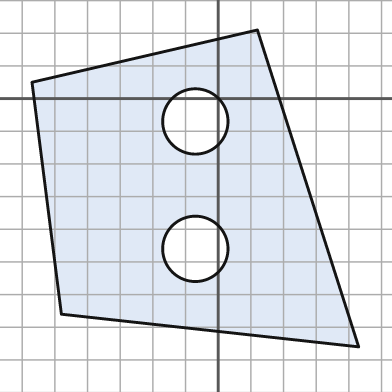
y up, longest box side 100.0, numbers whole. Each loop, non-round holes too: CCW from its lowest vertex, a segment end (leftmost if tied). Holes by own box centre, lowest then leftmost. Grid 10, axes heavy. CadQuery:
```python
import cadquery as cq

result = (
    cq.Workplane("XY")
    .moveTo(43.0, -76.0)
    .lineTo(12.0, 21.0)
    .lineTo(-57.0, 5.0)
    .lineTo(-48.0, -66.0)
    .close()
    .moveTo(-7.0, -46.0)
    .circle(10.0)
    .moveTo(-7.0, -7.0)
    .circle(10.0)
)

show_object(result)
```